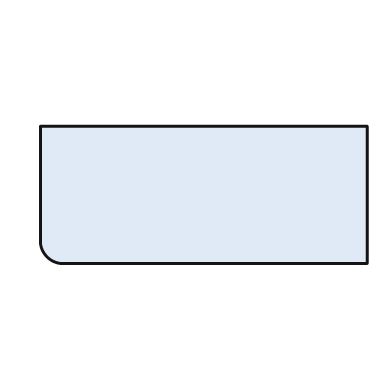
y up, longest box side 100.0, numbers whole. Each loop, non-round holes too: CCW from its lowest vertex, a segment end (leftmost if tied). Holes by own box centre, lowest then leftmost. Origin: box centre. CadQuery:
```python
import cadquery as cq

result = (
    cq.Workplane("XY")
    .moveTo(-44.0, -21.0)
    .lineTo(50.0, -21.0)
    .lineTo(50.0, 21.0)
    .lineTo(-50.0, 21.0)
    .lineTo(-50.0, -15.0)
    .threePointArc((-48.0, -19.0), (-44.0, -21.0))
    .close()
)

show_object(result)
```